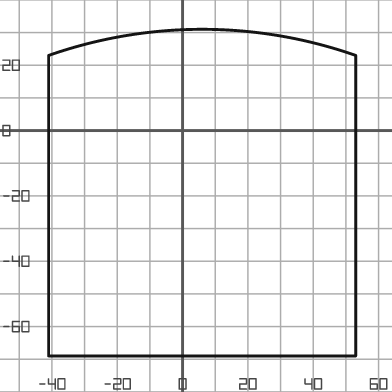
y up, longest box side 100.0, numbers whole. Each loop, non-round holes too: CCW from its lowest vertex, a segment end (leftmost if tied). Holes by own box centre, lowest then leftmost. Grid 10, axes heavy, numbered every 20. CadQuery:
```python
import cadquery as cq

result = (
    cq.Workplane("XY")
    .moveTo(-41.0, -69.0)
    .lineTo(53.0, -69.0)
    .lineTo(53.0, 23.0)
    .threePointArc((6.0, 31.0), (-41.0, 23.0))
    .close()
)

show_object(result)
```